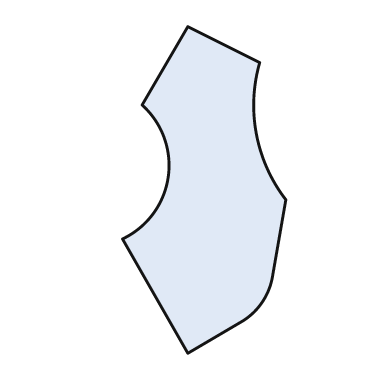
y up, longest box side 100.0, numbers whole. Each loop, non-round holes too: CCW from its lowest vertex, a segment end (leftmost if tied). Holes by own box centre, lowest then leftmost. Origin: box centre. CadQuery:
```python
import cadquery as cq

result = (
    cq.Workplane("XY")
    .moveTo(-5.0, -50.0)
    .lineTo(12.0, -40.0)
    .threePointArc((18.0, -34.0), (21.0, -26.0))
    .lineTo(25.0, -3.0)
    .threePointArc((16.0, 17.0), (17.0, 39.0))
    .lineTo(-5.0, 50.0)
    .lineTo(-19.0, 26.0)
    .threePointArc((-11.0, 4.0), (-25.0, -15.0))
    .close()
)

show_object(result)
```